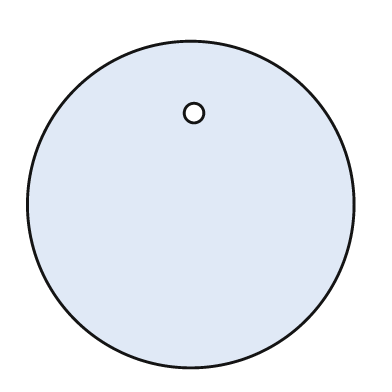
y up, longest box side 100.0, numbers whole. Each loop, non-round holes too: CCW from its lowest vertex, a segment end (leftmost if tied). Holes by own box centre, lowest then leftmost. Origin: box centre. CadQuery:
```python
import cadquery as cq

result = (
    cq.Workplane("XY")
    .moveTo(0.0, 0.0)
    .circle(50.0)
    .moveTo(1.0, 28.0)
    .circle(3.0)
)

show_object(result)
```